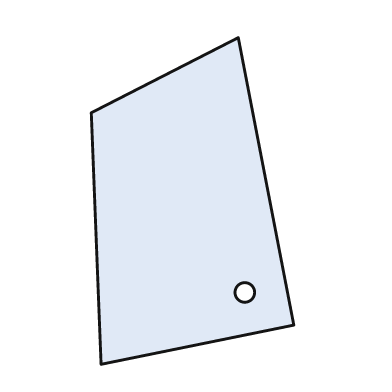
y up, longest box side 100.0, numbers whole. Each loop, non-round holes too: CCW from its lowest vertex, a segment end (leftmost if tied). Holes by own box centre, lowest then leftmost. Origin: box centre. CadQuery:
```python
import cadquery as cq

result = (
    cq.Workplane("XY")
    .moveTo(-28.0, -50.0)
    .lineTo(31.0, -38.0)
    .lineTo(14.0, 50.0)
    .lineTo(-31.0, 27.0)
    .close()
    .moveTo(16.0, -28.0)
    .circle(3.0)
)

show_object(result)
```